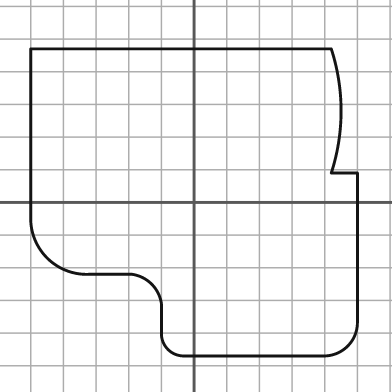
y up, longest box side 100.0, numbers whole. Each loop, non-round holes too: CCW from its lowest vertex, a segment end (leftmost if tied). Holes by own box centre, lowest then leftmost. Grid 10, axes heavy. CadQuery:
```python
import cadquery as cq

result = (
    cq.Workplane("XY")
    .moveTo(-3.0, -47.0)
    .lineTo(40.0, -47.0)
    .threePointArc((47.0, -44.0), (50.0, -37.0))
    .lineTo(50.0, 9.0)
    .lineTo(42.0, 9.0)
    .threePointArc((45.0, 28.0), (42.0, 47.0))
    .lineTo(-50.0, 47.0)
    .lineTo(-50.0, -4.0)
    .threePointArc((-45.0, -17.0), (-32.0, -22.0))
    .lineTo(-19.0, -22.0)
    .threePointArc((-13.0, -25.0), (-10.0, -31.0))
    .lineTo(-10.0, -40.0)
    .threePointArc((-8.0, -45.0), (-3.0, -47.0))
    .close()
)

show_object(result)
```